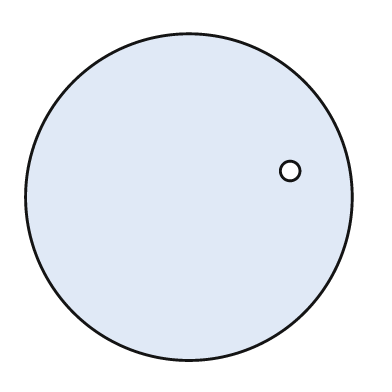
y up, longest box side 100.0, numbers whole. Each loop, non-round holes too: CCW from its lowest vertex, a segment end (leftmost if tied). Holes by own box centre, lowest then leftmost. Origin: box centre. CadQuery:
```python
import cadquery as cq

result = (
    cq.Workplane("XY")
    .moveTo(0.0, 0.0)
    .circle(50.0)
    .moveTo(31.0, 8.0)
    .circle(3.0)
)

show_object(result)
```